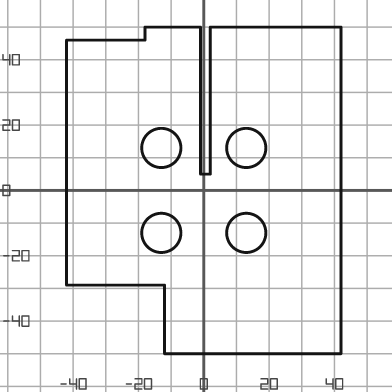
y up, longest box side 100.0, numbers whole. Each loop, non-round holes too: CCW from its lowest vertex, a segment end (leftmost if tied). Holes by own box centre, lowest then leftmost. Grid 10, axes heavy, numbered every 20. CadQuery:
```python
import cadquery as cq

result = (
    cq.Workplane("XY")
    .moveTo(-12.0, -50.0)
    .lineTo(42.0, -50.0)
    .lineTo(42.0, 50.0)
    .lineTo(2.0, 50.0)
    .lineTo(2.0, 5.0)
    .lineTo(-1.0, 5.0)
    .lineTo(-1.0, 50.0)
    .lineTo(-18.0, 50.0)
    .lineTo(-18.0, 46.0)
    .lineTo(-42.0, 46.0)
    .lineTo(-42.0, -29.0)
    .lineTo(-12.0, -29.0)
    .close()
    .moveTo(-13.0, -13.0)
    .circle(6.0)
    .moveTo(13.0, -13.0)
    .circle(6.0)
    .moveTo(-13.0, 13.0)
    .circle(6.0)
    .moveTo(13.0, 13.0)
    .circle(6.0)
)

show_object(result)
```